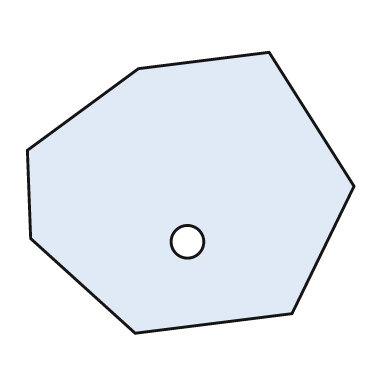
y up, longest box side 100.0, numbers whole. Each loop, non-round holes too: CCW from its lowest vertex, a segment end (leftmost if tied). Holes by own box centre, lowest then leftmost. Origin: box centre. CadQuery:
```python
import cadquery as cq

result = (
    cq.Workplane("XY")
    .moveTo(-17.0, -43.0)
    .lineTo(31.0, -37.0)
    .lineTo(50.0, 2.0)
    .lineTo(24.0, 43.0)
    .lineTo(-16.0, 38.0)
    .lineTo(-50.0, 13.0)
    .lineTo(-49.0, -14.0)
    .close()
    .moveTo(-1.0, -15.0)
    .circle(5.0)
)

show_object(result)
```